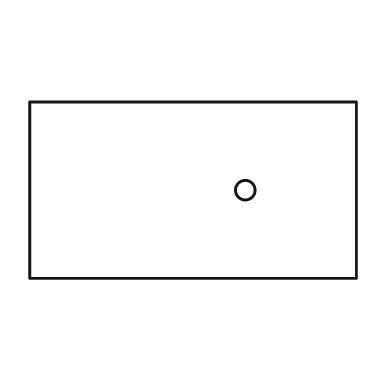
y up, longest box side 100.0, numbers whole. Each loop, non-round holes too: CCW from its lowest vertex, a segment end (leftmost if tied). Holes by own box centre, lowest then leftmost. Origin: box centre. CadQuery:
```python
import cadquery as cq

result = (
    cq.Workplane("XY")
    .moveTo(-50.0, -27.0)
    .lineTo(50.0, -27.0)
    .lineTo(50.0, 27.0)
    .lineTo(-50.0, 27.0)
    .close()
    .moveTo(16.0, 0.0)
    .circle(3.0)
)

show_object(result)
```